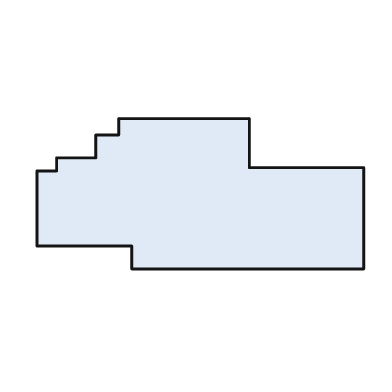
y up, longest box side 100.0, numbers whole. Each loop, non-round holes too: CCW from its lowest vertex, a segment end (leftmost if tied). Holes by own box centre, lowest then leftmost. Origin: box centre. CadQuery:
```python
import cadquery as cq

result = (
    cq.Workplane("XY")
    .moveTo(-21.0, -23.0)
    .lineTo(50.0, -23.0)
    .lineTo(50.0, 8.0)
    .lineTo(15.0, 8.0)
    .lineTo(15.0, 23.0)
    .lineTo(-25.0, 23.0)
    .lineTo(-25.0, 18.0)
    .lineTo(-32.0, 18.0)
    .lineTo(-32.0, 11.0)
    .lineTo(-44.0, 11.0)
    .lineTo(-44.0, 7.0)
    .lineTo(-50.0, 7.0)
    .lineTo(-50.0, -16.0)
    .lineTo(-21.0, -16.0)
    .close()
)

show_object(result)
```